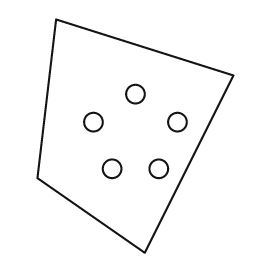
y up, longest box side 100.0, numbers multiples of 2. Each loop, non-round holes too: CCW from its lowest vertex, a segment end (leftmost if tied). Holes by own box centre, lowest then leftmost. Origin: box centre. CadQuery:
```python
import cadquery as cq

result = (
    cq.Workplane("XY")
    .moveTo(4.0, -50.0)
    .lineTo(42.0, 26.0)
    .lineTo(-34.0, 50.0)
    .lineTo(-42.0, -18.0)
    .close()
    .moveTo(-10.0, -14.0)
    .circle(4.0)
    .moveTo(10.0, -14.0)
    .circle(4.0)
    .moveTo(-18.0, 6.0)
    .circle(4.0)
    .moveTo(18.0, 6.0)
    .circle(4.0)
    .moveTo(0.0, 18.0)
    .circle(4.0)
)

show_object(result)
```